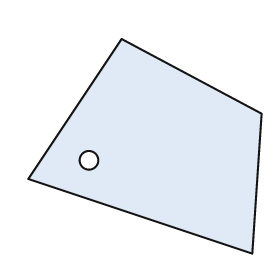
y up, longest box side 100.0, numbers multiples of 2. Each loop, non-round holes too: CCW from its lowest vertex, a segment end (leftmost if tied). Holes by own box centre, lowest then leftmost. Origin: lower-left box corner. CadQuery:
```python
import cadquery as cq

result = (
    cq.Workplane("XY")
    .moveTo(96.0, 0.0)
    .lineTo(100.0, 60.0)
    .lineTo(40.0, 92.0)
    .lineTo(0.0, 32.0)
    .close()
    .moveTo(26.0, 40.0)
    .circle(4.0)
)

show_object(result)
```